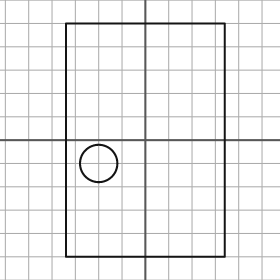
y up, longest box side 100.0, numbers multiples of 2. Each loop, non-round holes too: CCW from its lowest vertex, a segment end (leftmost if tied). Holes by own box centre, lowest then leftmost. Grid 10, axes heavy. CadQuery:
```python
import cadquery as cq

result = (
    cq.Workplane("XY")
    .moveTo(-34.0, -50.0)
    .lineTo(34.0, -50.0)
    .lineTo(34.0, 50.0)
    .lineTo(-34.0, 50.0)
    .close()
    .moveTo(-20.0, -10.0)
    .circle(8.0)
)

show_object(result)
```